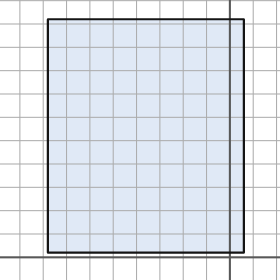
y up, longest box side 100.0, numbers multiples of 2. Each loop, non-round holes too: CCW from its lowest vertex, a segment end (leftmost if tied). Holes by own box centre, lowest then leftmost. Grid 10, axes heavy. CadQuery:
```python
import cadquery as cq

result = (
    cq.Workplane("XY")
    .moveTo(-78.0, 2.0)
    .lineTo(6.0, 2.0)
    .lineTo(6.0, 102.0)
    .lineTo(-78.0, 102.0)
    .close()
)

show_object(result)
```